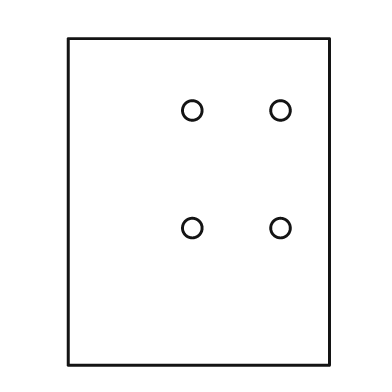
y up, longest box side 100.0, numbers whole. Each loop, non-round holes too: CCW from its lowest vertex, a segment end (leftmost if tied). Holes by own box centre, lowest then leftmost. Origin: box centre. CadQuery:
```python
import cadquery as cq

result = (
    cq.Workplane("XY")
    .moveTo(-40.0, -50.0)
    .lineTo(40.0, -50.0)
    .lineTo(40.0, 50.0)
    .lineTo(-40.0, 50.0)
    .close()
    .moveTo(-2.0, -8.0)
    .circle(3.0)
    .moveTo(25.0, -8.0)
    .circle(3.0)
    .moveTo(-2.0, 28.0)
    .circle(3.0)
    .moveTo(25.0, 28.0)
    .circle(3.0)
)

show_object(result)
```